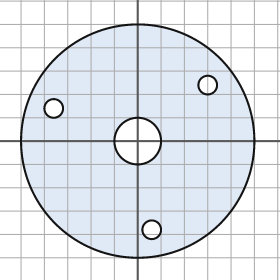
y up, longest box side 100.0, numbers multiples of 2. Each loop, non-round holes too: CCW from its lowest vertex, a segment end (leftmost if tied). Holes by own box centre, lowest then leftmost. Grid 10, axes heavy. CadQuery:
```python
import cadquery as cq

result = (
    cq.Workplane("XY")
    .moveTo(0.0, 0.0)
    .circle(50.0)
    .moveTo(6.0, -38.0)
    .circle(4.0)
    .moveTo(0.0, 0.0)
    .circle(10.0)
    .moveTo(-36.0, 14.0)
    .circle(4.0)
    .moveTo(30.0, 24.0)
    .circle(4.0)
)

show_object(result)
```